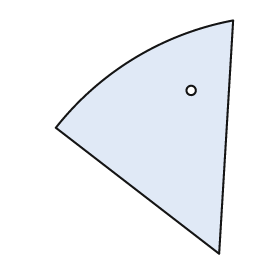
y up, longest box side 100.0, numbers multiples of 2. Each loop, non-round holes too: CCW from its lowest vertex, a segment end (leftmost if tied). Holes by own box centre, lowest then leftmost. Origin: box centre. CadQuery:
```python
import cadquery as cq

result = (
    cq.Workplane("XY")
    .moveTo(32.0, -50.0)
    .lineTo(38.0, 50.0)
    .threePointArc((-4.0, 34.0), (-38.0, 4.0))
    .close()
    .moveTo(20.0, 20.0)
    .circle(2.0)
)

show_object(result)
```